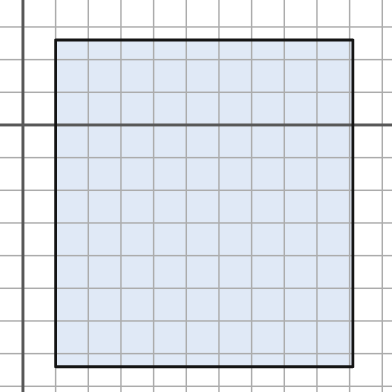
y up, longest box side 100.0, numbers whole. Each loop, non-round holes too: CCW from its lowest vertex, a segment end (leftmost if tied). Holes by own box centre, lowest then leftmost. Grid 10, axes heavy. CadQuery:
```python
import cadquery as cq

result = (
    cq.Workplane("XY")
    .moveTo(10.0, -74.0)
    .lineTo(101.0, -74.0)
    .lineTo(101.0, 26.0)
    .lineTo(10.0, 26.0)
    .close()
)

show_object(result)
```